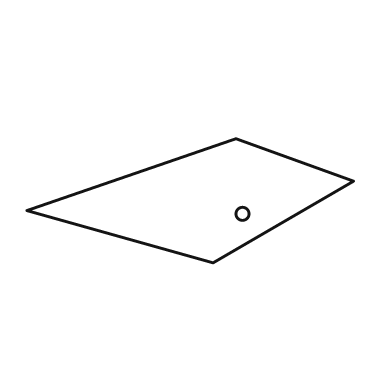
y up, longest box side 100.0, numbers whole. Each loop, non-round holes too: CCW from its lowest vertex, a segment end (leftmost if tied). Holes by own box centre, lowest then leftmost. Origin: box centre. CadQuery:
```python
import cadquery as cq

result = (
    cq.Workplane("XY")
    .moveTo(7.0, -19.0)
    .lineTo(50.0, 6.0)
    .lineTo(14.0, 19.0)
    .lineTo(-50.0, -3.0)
    .close()
    .moveTo(16.0, -4.0)
    .circle(2.0)
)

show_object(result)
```